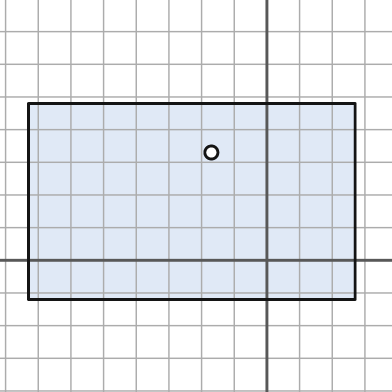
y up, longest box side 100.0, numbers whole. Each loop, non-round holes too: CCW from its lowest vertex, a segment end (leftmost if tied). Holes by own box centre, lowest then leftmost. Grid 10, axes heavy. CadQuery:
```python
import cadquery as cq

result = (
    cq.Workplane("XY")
    .moveTo(-73.0, -12.0)
    .lineTo(27.0, -12.0)
    .lineTo(27.0, 48.0)
    .lineTo(-73.0, 48.0)
    .close()
    .moveTo(-17.0, 33.0)
    .circle(2.0)
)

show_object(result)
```